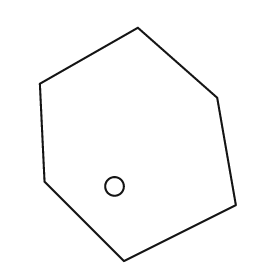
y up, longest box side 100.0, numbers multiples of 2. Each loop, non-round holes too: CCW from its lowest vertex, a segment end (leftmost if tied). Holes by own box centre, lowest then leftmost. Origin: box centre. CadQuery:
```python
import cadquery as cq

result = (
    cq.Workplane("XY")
    .moveTo(-6.0, -50.0)
    .lineTo(42.0, -26.0)
    .lineTo(34.0, 20.0)
    .lineTo(0.0, 50.0)
    .lineTo(-42.0, 26.0)
    .lineTo(-40.0, -16.0)
    .close()
    .moveTo(-10.0, -18.0)
    .circle(4.0)
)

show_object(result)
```